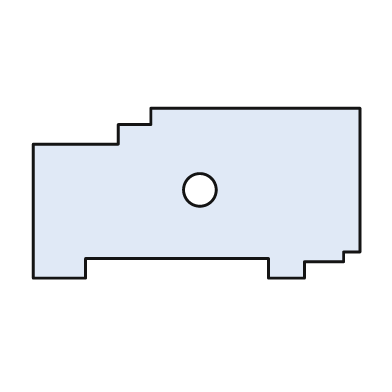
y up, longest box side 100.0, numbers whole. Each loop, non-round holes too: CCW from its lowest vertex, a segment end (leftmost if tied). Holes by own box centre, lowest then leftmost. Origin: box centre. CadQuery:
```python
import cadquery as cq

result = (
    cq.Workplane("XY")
    .moveTo(-50.0, -26.0)
    .lineTo(-34.0, -26.0)
    .lineTo(-34.0, -20.0)
    .lineTo(22.0, -20.0)
    .lineTo(22.0, -26.0)
    .lineTo(33.0, -26.0)
    .lineTo(33.0, -21.0)
    .lineTo(45.0, -21.0)
    .lineTo(45.0, -18.0)
    .lineTo(50.0, -18.0)
    .lineTo(50.0, 26.0)
    .lineTo(-14.0, 26.0)
    .lineTo(-14.0, 21.0)
    .lineTo(-24.0, 21.0)
    .lineTo(-24.0, 15.0)
    .lineTo(-50.0, 15.0)
    .close()
    .moveTo(1.0, 1.0)
    .circle(5.0)
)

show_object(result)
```